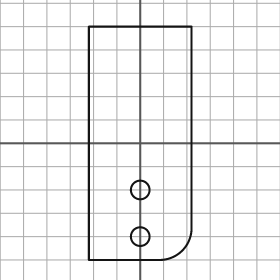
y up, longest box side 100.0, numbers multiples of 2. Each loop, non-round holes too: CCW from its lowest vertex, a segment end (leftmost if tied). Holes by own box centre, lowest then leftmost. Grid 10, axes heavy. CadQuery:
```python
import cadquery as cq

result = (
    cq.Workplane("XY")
    .moveTo(-22.0, -50.0)
    .lineTo(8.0, -50.0)
    .threePointArc((18.0, -46.0), (22.0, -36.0))
    .lineTo(22.0, 50.0)
    .lineTo(-22.0, 50.0)
    .close()
    .moveTo(0.0, -40.0)
    .circle(4.0)
    .moveTo(0.0, -20.0)
    .circle(4.0)
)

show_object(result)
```